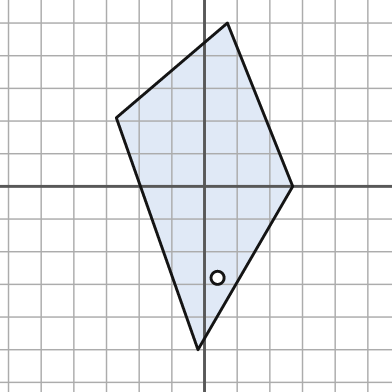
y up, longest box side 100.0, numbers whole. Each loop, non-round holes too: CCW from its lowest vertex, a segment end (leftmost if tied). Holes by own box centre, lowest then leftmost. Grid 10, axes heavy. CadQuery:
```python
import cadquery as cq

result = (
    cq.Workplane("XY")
    .moveTo(-2.0, -50.0)
    .lineTo(27.0, 0.0)
    .lineTo(7.0, 50.0)
    .lineTo(-27.0, 21.0)
    .close()
    .moveTo(4.0, -28.0)
    .circle(2.0)
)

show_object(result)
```